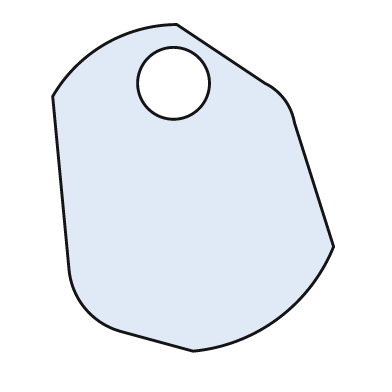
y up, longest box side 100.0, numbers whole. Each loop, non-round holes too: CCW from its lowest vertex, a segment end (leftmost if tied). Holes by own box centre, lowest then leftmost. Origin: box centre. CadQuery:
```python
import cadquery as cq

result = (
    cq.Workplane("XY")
    .moveTo(0.0, -50.0)
    .threePointArc((26.0, -40.0), (43.0, -18.0))
    .lineTo(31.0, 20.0)
    .threePointArc((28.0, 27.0), (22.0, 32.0))
    .lineTo(-5.0, 50.0)
    .threePointArc((-27.0, 44.0), (-43.0, 28.0))
    .lineTo(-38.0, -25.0)
    .threePointArc((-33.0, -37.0), (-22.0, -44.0))
    .close()
    .moveTo(-6.0, 32.0)
    .circle(11.0)
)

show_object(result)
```